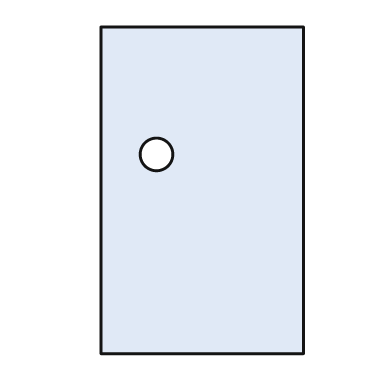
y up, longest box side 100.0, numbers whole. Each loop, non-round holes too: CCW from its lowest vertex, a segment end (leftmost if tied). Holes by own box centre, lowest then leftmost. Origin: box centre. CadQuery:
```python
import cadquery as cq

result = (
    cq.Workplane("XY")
    .moveTo(-31.0, -50.0)
    .lineTo(31.0, -50.0)
    .lineTo(31.0, 50.0)
    .lineTo(-31.0, 50.0)
    .close()
    .moveTo(-14.0, 11.0)
    .circle(5.0)
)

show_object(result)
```